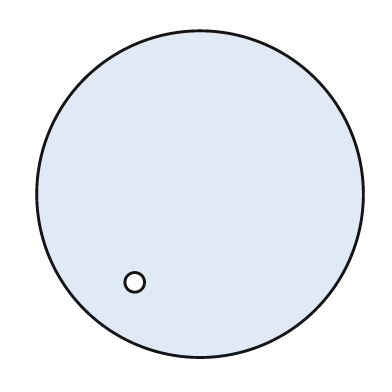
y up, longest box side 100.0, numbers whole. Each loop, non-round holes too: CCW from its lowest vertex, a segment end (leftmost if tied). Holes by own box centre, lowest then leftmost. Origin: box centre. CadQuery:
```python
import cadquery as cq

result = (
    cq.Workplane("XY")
    .moveTo(0.0, 0.0)
    .circle(50.0)
    .moveTo(-20.0, -27.0)
    .circle(3.0)
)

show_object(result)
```